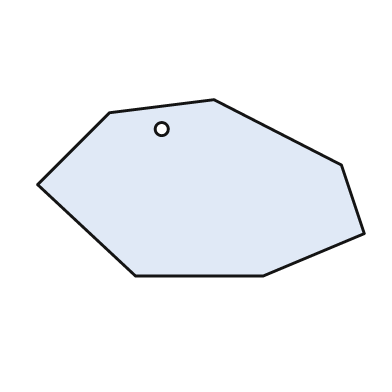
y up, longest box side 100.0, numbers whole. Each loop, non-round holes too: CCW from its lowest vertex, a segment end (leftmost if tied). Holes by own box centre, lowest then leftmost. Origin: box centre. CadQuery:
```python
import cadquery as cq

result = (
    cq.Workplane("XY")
    .moveTo(-20.0, -27.0)
    .lineTo(19.0, -27.0)
    .lineTo(50.0, -14.0)
    .lineTo(43.0, 7.0)
    .lineTo(4.0, 27.0)
    .lineTo(-28.0, 23.0)
    .lineTo(-50.0, 1.0)
    .close()
    .moveTo(-12.0, 18.0)
    .circle(2.0)
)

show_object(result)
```